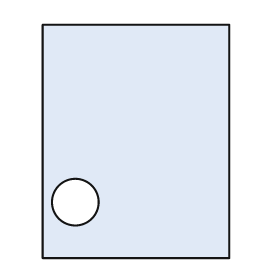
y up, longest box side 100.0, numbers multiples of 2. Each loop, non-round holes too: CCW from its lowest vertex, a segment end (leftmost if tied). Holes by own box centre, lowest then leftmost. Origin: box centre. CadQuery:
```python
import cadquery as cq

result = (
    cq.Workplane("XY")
    .moveTo(-40.0, -50.0)
    .lineTo(40.0, -50.0)
    .lineTo(40.0, 50.0)
    .lineTo(-40.0, 50.0)
    .close()
    .moveTo(-26.0, -26.0)
    .circle(10.0)
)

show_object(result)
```